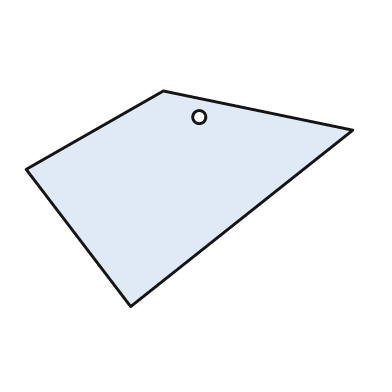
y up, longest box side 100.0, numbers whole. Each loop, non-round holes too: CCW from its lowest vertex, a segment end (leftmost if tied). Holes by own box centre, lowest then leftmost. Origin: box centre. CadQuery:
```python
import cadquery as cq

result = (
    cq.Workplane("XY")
    .moveTo(-18.0, -33.0)
    .lineTo(50.0, 21.0)
    .lineTo(-8.0, 33.0)
    .lineTo(-50.0, 9.0)
    .close()
    .moveTo(3.0, 25.0)
    .circle(2.0)
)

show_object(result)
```